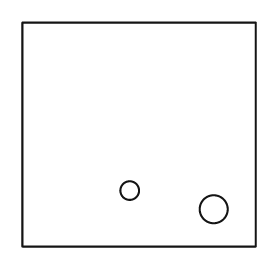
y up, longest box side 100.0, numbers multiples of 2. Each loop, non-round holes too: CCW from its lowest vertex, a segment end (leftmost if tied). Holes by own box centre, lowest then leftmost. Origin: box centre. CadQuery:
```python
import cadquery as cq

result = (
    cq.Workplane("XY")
    .moveTo(-50.0, -48.0)
    .lineTo(50.0, -48.0)
    .lineTo(50.0, 48.0)
    .lineTo(-50.0, 48.0)
    .close()
    .moveTo(32.0, -32.0)
    .circle(6.0)
    .moveTo(-4.0, -24.0)
    .circle(4.0)
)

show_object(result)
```